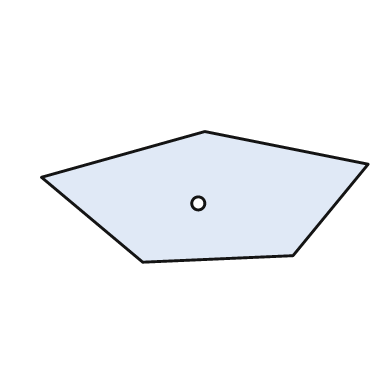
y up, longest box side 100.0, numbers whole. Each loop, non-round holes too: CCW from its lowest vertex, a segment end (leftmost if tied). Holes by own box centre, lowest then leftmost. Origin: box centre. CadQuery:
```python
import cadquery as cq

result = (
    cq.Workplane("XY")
    .moveTo(-19.0, -20.0)
    .lineTo(27.0, -18.0)
    .lineTo(50.0, 10.0)
    .lineTo(0.0, 20.0)
    .lineTo(-50.0, 6.0)
    .close()
    .moveTo(-2.0, -2.0)
    .circle(2.0)
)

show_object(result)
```